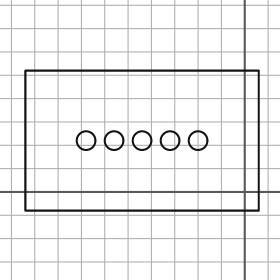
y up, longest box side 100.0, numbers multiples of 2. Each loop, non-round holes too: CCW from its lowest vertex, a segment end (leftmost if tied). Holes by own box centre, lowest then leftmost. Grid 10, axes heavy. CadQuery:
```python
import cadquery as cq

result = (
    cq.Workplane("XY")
    .moveTo(-94.0, -8.0)
    .lineTo(6.0, -8.0)
    .lineTo(6.0, 52.0)
    .lineTo(-94.0, 52.0)
    .close()
    .moveTo(-68.0, 22.0)
    .circle(4.0)
    .moveTo(-56.0, 22.0)
    .circle(4.0)
    .moveTo(-44.0, 22.0)
    .circle(4.0)
    .moveTo(-32.0, 22.0)
    .circle(4.0)
    .moveTo(-20.0, 22.0)
    .circle(4.0)
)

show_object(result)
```